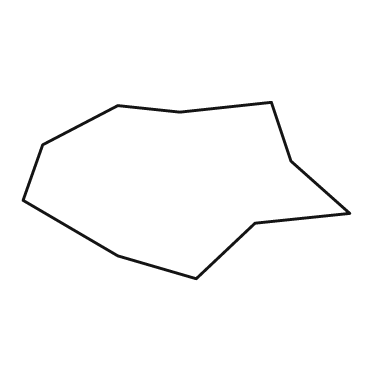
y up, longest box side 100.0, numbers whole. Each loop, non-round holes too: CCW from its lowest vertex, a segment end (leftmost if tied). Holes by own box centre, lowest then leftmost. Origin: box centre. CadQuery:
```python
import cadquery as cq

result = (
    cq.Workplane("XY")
    .moveTo(3.0, -27.0)
    .lineTo(21.0, -10.0)
    .lineTo(50.0, -7.0)
    .lineTo(32.0, 9.0)
    .lineTo(26.0, 27.0)
    .lineTo(-2.0, 24.0)
    .lineTo(-21.0, 26.0)
    .lineTo(-44.0, 14.0)
    .lineTo(-50.0, -3.0)
    .lineTo(-21.0, -20.0)
    .close()
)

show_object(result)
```